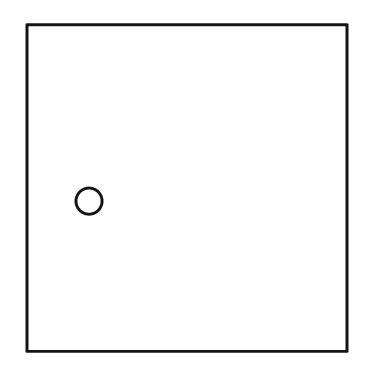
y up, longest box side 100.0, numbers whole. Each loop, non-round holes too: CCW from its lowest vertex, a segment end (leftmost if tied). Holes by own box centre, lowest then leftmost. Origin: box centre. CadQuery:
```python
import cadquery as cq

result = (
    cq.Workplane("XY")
    .moveTo(-49.0, -50.0)
    .lineTo(49.0, -50.0)
    .lineTo(49.0, 50.0)
    .lineTo(-49.0, 50.0)
    .close()
    .moveTo(-30.0, -4.0)
    .circle(4.0)
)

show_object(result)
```